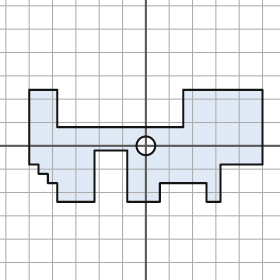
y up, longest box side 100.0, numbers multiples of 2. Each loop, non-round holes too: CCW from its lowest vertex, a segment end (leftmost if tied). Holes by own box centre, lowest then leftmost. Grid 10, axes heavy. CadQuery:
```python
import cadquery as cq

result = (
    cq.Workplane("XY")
    .moveTo(-38.0, -24.0)
    .lineTo(-22.0, -24.0)
    .lineTo(-22.0, -2.0)
    .lineTo(-8.0, -2.0)
    .lineTo(-8.0, -24.0)
    .lineTo(6.0, -24.0)
    .lineTo(6.0, -16.0)
    .lineTo(26.0, -16.0)
    .lineTo(26.0, -24.0)
    .lineTo(32.0, -24.0)
    .lineTo(32.0, -8.0)
    .lineTo(50.0, -8.0)
    .lineTo(50.0, 24.0)
    .lineTo(16.0, 24.0)
    .lineTo(16.0, 8.0)
    .lineTo(-38.0, 8.0)
    .lineTo(-38.0, 24.0)
    .lineTo(-50.0, 24.0)
    .lineTo(-50.0, -8.0)
    .lineTo(-46.0, -8.0)
    .lineTo(-46.0, -12.0)
    .lineTo(-42.0, -12.0)
    .lineTo(-42.0, -16.0)
    .lineTo(-38.0, -16.0)
    .close()
    .moveTo(0.0, 0.0)
    .circle(4.0)
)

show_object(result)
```